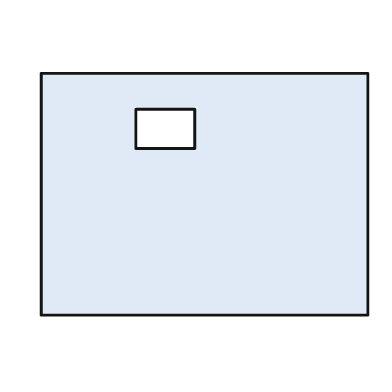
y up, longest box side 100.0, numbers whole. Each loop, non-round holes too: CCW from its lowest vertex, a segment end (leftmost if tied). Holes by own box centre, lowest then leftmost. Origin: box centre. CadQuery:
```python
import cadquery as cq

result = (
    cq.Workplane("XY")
    .moveTo(-50.0, -37.0)
    .lineTo(50.0, -37.0)
    .lineTo(50.0, 37.0)
    .lineTo(-50.0, 37.0)
    .close()
    .moveTo(-21.0, 14.0)
    .lineTo(-3.0, 14.0)
    .lineTo(-3.0, 26.0)
    .lineTo(-21.0, 26.0)
    .close()
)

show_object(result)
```